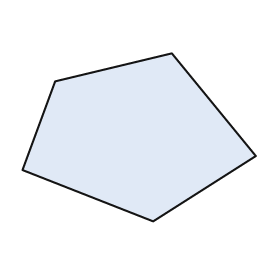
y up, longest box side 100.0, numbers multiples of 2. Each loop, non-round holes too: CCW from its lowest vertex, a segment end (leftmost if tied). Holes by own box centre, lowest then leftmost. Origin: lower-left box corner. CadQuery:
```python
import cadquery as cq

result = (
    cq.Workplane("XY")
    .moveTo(56.0, 0.0)
    .lineTo(100.0, 28.0)
    .lineTo(64.0, 72.0)
    .lineTo(14.0, 60.0)
    .lineTo(0.0, 22.0)
    .close()
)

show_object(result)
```